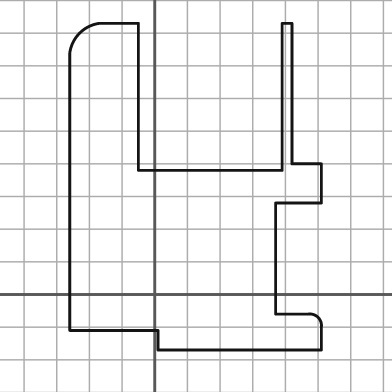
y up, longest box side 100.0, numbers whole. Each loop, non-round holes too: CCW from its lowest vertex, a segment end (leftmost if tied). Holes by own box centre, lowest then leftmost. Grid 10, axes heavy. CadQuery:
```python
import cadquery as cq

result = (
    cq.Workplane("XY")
    .moveTo(1.0, -17.0)
    .lineTo(51.0, -17.0)
    .lineTo(51.0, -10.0)
    .threePointArc((50.0, -7.0), (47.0, -6.0))
    .lineTo(37.0, -6.0)
    .lineTo(37.0, 28.0)
    .lineTo(51.0, 28.0)
    .lineTo(51.0, 40.0)
    .lineTo(42.0, 40.0)
    .lineTo(42.0, 83.0)
    .lineTo(39.0, 83.0)
    .lineTo(39.0, 38.0)
    .lineTo(-5.0, 38.0)
    .lineTo(-5.0, 83.0)
    .lineTo(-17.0, 83.0)
    .threePointArc((-23.0, 80.0), (-26.0, 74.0))
    .lineTo(-26.0, -11.0)
    .lineTo(1.0, -11.0)
    .close()
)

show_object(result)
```